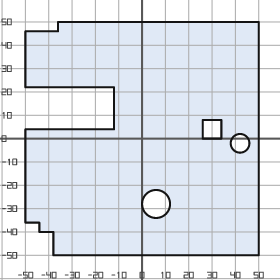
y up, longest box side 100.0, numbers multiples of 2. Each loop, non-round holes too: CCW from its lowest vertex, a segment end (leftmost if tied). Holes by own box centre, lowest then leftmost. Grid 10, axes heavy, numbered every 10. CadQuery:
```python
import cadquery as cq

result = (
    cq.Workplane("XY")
    .moveTo(-38.0, -50.0)
    .lineTo(50.0, -50.0)
    .lineTo(50.0, 50.0)
    .lineTo(-36.0, 50.0)
    .lineTo(-36.0, 46.0)
    .lineTo(-50.0, 46.0)
    .lineTo(-50.0, 22.0)
    .lineTo(-12.0, 22.0)
    .lineTo(-12.0, 4.0)
    .lineTo(-50.0, 4.0)
    .lineTo(-50.0, -36.0)
    .lineTo(-44.0, -36.0)
    .lineTo(-44.0, -40.0)
    .lineTo(-38.0, -40.0)
    .close()
    .moveTo(6.0, -28.0)
    .circle(6.0)
    .moveTo(42.0, -2.0)
    .circle(4.0)
    .moveTo(26.0, 0.0)
    .lineTo(34.0, 0.0)
    .lineTo(34.0, 8.0)
    .lineTo(26.0, 8.0)
    .close()
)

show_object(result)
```